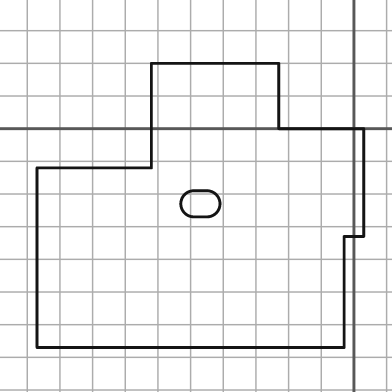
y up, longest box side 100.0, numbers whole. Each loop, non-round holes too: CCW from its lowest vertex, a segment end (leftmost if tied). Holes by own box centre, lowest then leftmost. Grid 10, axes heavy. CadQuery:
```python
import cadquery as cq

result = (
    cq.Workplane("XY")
    .moveTo(-97.0, -67.0)
    .lineTo(-3.0, -67.0)
    .lineTo(-3.0, -33.0)
    .lineTo(3.0, -33.0)
    .lineTo(3.0, 0.0)
    .lineTo(-23.0, 0.0)
    .lineTo(-23.0, 20.0)
    .lineTo(-62.0, 20.0)
    .lineTo(-62.0, -12.0)
    .lineTo(-97.0, -12.0)
    .close()
    .moveTo(-49.0, -27.0)
    .lineTo(-45.0, -27.0)
    .threePointArc((-41.0, -23.0), (-45.0, -19.0))
    .lineTo(-49.0, -19.0)
    .threePointArc((-53.0, -23.0), (-49.0, -27.0))
    .close()
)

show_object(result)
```